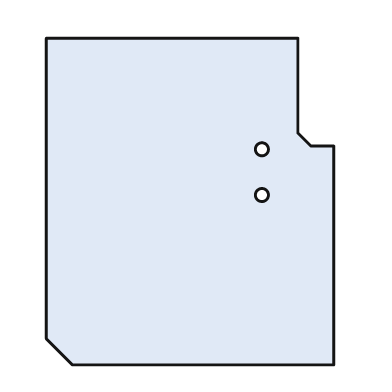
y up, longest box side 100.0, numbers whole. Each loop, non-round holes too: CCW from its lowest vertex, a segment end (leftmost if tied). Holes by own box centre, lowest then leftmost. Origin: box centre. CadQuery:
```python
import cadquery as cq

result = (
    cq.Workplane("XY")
    .moveTo(-36.0, -50.0)
    .lineTo(44.0, -50.0)
    .lineTo(44.0, 17.0)
    .lineTo(37.0, 17.0)
    .lineTo(33.0, 21.0)
    .lineTo(33.0, 50.0)
    .lineTo(-44.0, 50.0)
    .lineTo(-44.0, -42.0)
    .close()
    .moveTo(22.0, 2.0)
    .circle(2.0)
    .moveTo(22.0, 16.0)
    .circle(2.0)
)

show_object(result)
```